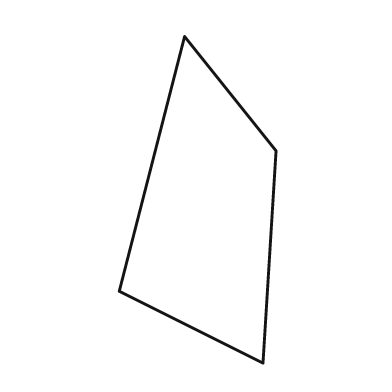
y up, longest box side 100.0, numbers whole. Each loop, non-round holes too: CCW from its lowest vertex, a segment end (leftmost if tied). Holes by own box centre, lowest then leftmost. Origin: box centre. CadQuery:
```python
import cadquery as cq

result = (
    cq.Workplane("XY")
    .moveTo(20.0, -50.0)
    .lineTo(24.0, 15.0)
    .lineTo(-4.0, 50.0)
    .lineTo(-24.0, -28.0)
    .close()
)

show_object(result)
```